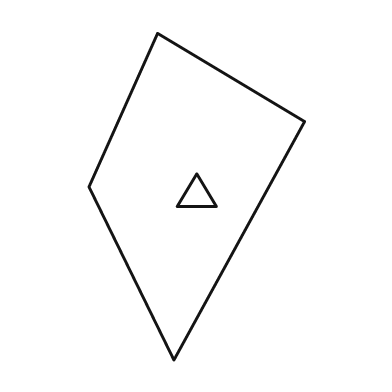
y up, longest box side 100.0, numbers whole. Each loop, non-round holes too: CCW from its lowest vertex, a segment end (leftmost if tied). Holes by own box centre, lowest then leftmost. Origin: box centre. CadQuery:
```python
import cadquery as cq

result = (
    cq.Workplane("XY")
    .moveTo(-7.0, -50.0)
    .lineTo(33.0, 23.0)
    .lineTo(-12.0, 50.0)
    .lineTo(-33.0, 3.0)
    .close()
    .moveTo(-6.0, -3.0)
    .lineTo(6.0, -3.0)
    .lineTo(0.0, 7.0)
    .close()
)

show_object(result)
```